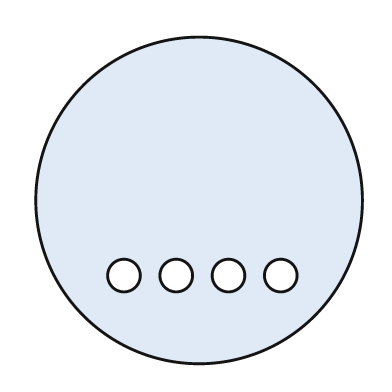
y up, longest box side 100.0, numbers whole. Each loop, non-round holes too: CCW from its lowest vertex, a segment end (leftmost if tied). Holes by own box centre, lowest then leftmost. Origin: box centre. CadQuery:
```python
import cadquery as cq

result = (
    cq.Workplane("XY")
    .moveTo(0.0, 0.0)
    .circle(50.0)
    .moveTo(-23.0, -23.0)
    .circle(5.0)
    .moveTo(-7.0, -23.0)
    .circle(5.0)
    .moveTo(9.0, -23.0)
    .circle(5.0)
    .moveTo(25.0, -23.0)
    .circle(5.0)
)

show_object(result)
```